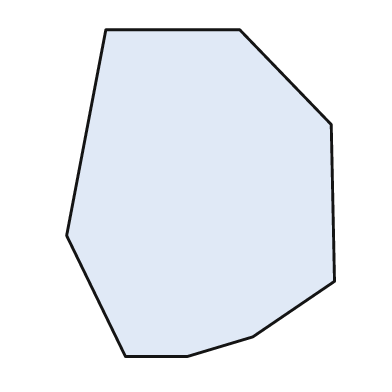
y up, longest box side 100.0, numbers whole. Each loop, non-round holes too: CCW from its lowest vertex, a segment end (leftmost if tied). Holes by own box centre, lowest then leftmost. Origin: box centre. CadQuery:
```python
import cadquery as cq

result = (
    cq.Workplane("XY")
    .moveTo(-23.0, -50.0)
    .lineTo(-4.0, -50.0)
    .lineTo(16.0, -44.0)
    .lineTo(41.0, -27.0)
    .lineTo(40.0, 21.0)
    .lineTo(12.0, 50.0)
    .lineTo(-29.0, 50.0)
    .lineTo(-41.0, -13.0)
    .close()
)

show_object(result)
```